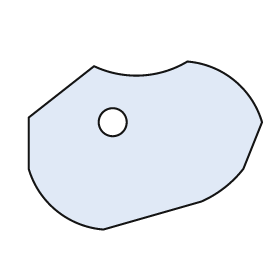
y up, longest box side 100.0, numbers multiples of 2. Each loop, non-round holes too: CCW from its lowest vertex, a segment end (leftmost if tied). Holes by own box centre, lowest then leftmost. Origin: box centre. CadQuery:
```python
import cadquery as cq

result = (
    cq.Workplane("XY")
    .moveTo(-18.0, -36.0)
    .lineTo(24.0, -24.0)
    .threePointArc((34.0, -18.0), (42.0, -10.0))
    .lineTo(50.0, 10.0)
    .threePointArc((38.0, 28.0), (18.0, 36.0))
    .threePointArc((-2.0, 30.0), (-22.0, 34.0))
    .lineTo(-50.0, 12.0)
    .lineTo(-50.0, -10.0)
    .threePointArc((-38.0, -28.0), (-18.0, -36.0))
    .close()
    .moveTo(-14.0, 10.0)
    .circle(6.0)
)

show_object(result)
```